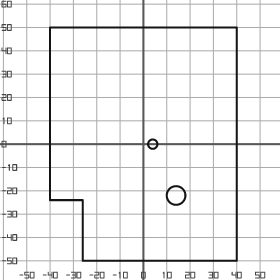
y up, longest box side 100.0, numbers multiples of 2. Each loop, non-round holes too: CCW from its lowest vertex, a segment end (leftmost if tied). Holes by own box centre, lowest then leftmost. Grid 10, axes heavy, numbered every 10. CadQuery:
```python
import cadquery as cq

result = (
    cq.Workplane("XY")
    .moveTo(-26.0, -50.0)
    .lineTo(40.0, -50.0)
    .lineTo(40.0, 50.0)
    .lineTo(-40.0, 50.0)
    .lineTo(-40.0, -24.0)
    .lineTo(-26.0, -24.0)
    .close()
    .moveTo(14.0, -22.0)
    .circle(4.0)
    .moveTo(4.0, 0.0)
    .circle(2.0)
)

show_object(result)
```